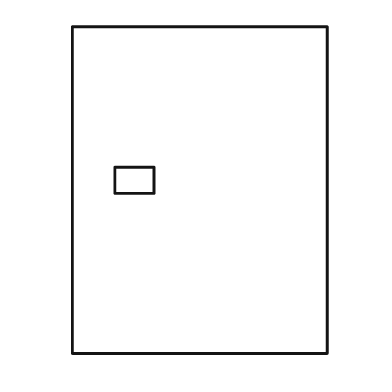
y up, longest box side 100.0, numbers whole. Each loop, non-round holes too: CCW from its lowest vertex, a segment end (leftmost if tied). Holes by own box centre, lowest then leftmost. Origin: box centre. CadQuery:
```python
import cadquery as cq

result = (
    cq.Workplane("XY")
    .moveTo(-39.0, -50.0)
    .lineTo(39.0, -50.0)
    .lineTo(39.0, 50.0)
    .lineTo(-39.0, 50.0)
    .close()
    .moveTo(-26.0, -1.0)
    .lineTo(-14.0, -1.0)
    .lineTo(-14.0, 7.0)
    .lineTo(-26.0, 7.0)
    .close()
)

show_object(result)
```